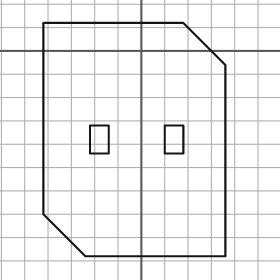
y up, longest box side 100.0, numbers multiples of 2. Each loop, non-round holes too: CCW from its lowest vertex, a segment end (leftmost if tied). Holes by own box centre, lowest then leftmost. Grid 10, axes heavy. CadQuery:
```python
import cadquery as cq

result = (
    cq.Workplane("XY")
    .moveTo(-24.0, -88.0)
    .lineTo(36.0, -88.0)
    .lineTo(36.0, -6.0)
    .lineTo(18.0, 12.0)
    .lineTo(-42.0, 12.0)
    .lineTo(-42.0, -70.0)
    .close()
    .moveTo(-22.0, -44.0)
    .lineTo(-14.0, -44.0)
    .lineTo(-14.0, -32.0)
    .lineTo(-22.0, -32.0)
    .close()
    .moveTo(10.0, -44.0)
    .lineTo(18.0, -44.0)
    .lineTo(18.0, -32.0)
    .lineTo(10.0, -32.0)
    .close()
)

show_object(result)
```